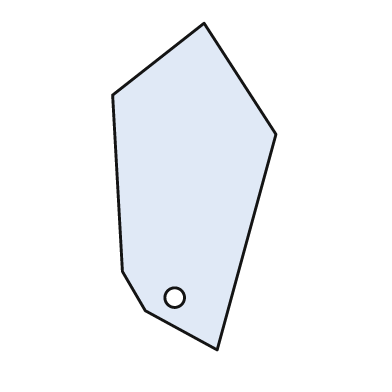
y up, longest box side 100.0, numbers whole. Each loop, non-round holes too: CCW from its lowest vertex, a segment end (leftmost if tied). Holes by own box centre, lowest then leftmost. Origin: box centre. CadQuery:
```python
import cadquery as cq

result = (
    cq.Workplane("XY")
    .moveTo(7.0, -50.0)
    .lineTo(25.0, 16.0)
    .lineTo(3.0, 50.0)
    .lineTo(-25.0, 28.0)
    .lineTo(-22.0, -26.0)
    .lineTo(-15.0, -38.0)
    .close()
    .moveTo(-6.0, -34.0)
    .circle(3.0)
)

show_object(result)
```